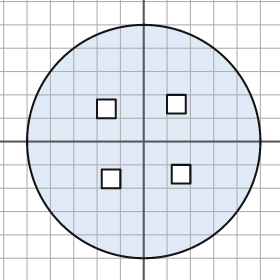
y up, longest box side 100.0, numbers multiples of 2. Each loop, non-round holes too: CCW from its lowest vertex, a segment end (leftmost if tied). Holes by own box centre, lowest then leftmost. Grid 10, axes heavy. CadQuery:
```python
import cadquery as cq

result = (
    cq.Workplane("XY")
    .moveTo(0.0, 0.0)
    .circle(50.0)
    .moveTo(-18.0, -20.0)
    .lineTo(-10.0, -20.0)
    .lineTo(-10.0, -12.0)
    .lineTo(-18.0, -12.0)
    .close()
    .moveTo(12.0, -18.0)
    .lineTo(20.0, -18.0)
    .lineTo(20.0, -10.0)
    .lineTo(12.0, -10.0)
    .close()
    .moveTo(-20.0, 10.0)
    .lineTo(-12.0, 10.0)
    .lineTo(-12.0, 18.0)
    .lineTo(-20.0, 18.0)
    .close()
    .moveTo(10.0, 12.0)
    .lineTo(18.0, 12.0)
    .lineTo(18.0, 20.0)
    .lineTo(10.0, 20.0)
    .close()
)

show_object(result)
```